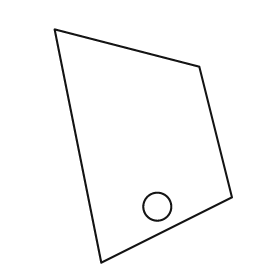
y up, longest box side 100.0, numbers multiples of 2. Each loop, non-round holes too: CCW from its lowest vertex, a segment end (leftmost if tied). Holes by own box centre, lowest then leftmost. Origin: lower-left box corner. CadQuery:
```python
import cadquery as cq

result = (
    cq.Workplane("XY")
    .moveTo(20.0, 0.0)
    .lineTo(76.0, 28.0)
    .lineTo(62.0, 84.0)
    .lineTo(0.0, 100.0)
    .close()
    .moveTo(44.0, 24.0)
    .circle(6.0)
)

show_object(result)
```